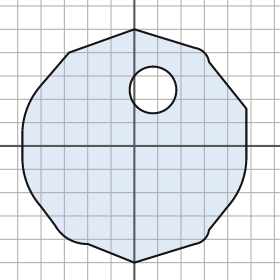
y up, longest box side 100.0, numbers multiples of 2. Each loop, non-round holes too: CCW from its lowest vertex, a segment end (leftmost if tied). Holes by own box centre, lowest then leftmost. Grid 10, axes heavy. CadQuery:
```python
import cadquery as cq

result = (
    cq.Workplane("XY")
    .moveTo(0.0, -50.0)
    .lineTo(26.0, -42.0)
    .threePointArc((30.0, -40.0), (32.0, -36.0))
    .lineTo(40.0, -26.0)
    .threePointArc((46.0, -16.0), (48.0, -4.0))
    .lineTo(48.0, 16.0)
    .lineTo(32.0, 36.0)
    .threePointArc((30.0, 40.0), (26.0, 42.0))
    .lineTo(0.0, 50.0)
    .lineTo(-28.0, 40.0)
    .lineTo(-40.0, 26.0)
    .threePointArc((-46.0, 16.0), (-48.0, 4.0))
    .lineTo(-48.0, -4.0)
    .threePointArc((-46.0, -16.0), (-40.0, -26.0))
    .lineTo(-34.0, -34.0)
    .threePointArc((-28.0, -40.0), (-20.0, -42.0))
    .close()
    .moveTo(8.0, 24.0)
    .circle(10.0)
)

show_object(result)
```